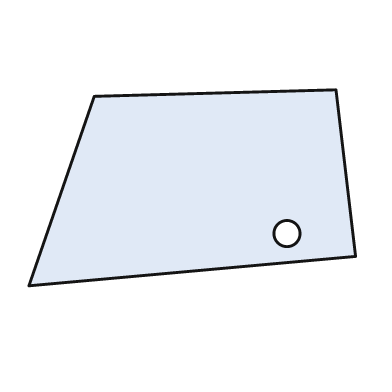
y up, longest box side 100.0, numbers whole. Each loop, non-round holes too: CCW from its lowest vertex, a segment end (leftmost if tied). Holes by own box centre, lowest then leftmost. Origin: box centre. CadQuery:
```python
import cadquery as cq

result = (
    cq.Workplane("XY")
    .moveTo(-50.0, -30.0)
    .lineTo(50.0, -21.0)
    .lineTo(44.0, 30.0)
    .lineTo(-30.0, 28.0)
    .close()
    .moveTo(29.0, -14.0)
    .circle(4.0)
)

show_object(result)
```